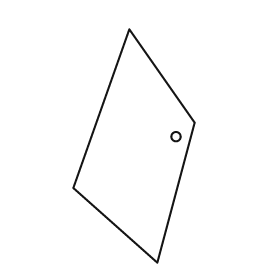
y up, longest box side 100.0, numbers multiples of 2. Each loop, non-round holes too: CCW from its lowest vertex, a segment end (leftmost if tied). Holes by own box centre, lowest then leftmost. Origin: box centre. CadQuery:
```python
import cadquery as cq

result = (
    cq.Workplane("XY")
    .moveTo(10.0, -50.0)
    .lineTo(26.0, 10.0)
    .lineTo(-2.0, 50.0)
    .lineTo(-26.0, -18.0)
    .close()
    .moveTo(18.0, 4.0)
    .circle(2.0)
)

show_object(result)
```